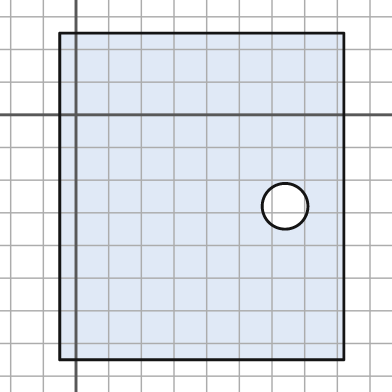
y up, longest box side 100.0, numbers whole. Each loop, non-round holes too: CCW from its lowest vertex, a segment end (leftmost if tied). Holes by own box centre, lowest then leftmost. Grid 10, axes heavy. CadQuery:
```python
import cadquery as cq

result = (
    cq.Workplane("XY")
    .moveTo(-5.0, -75.0)
    .lineTo(82.0, -75.0)
    .lineTo(82.0, 25.0)
    .lineTo(-5.0, 25.0)
    .close()
    .moveTo(64.0, -28.0)
    .circle(7.0)
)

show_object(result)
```